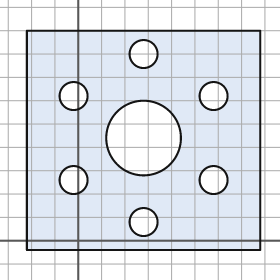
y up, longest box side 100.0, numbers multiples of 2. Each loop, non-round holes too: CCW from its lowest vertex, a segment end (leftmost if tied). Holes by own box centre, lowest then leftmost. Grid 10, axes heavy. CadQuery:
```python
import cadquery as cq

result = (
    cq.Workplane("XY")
    .moveTo(-22.0, -4.0)
    .lineTo(78.0, -4.0)
    .lineTo(78.0, 90.0)
    .lineTo(-22.0, 90.0)
    .close()
    .moveTo(28.0, 8.0)
    .circle(6.0)
    .moveTo(-2.0, 26.0)
    .circle(6.0)
    .moveTo(58.0, 26.0)
    .circle(6.0)
    .moveTo(28.0, 44.0)
    .circle(16.0)
    .moveTo(-2.0, 62.0)
    .circle(6.0)
    .moveTo(58.0, 62.0)
    .circle(6.0)
    .moveTo(28.0, 80.0)
    .circle(6.0)
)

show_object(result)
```